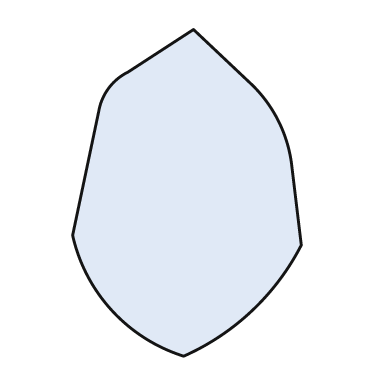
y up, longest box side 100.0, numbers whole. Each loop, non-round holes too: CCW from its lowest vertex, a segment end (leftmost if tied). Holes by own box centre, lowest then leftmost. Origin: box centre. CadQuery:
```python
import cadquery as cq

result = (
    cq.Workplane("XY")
    .moveTo(-1.0, -50.0)
    .threePointArc((20.0, -36.0), (35.0, -16.0))
    .lineTo(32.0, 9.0)
    .threePointArc((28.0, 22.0), (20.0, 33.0))
    .lineTo(2.0, 50.0)
    .lineTo(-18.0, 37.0)
    .threePointArc((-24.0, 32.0), (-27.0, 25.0))
    .lineTo(-35.0, -13.0)
    .threePointArc((-23.0, -36.0), (-1.0, -50.0))
    .close()
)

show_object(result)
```